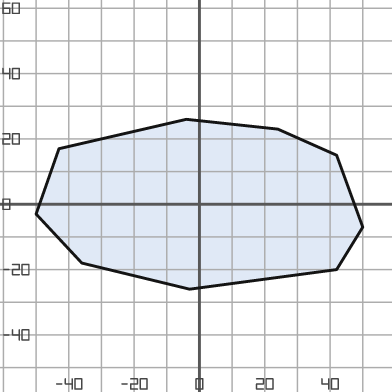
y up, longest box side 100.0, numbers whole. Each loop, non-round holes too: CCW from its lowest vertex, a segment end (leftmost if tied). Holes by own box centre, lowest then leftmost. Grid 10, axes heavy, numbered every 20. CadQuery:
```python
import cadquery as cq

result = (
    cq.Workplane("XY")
    .moveTo(-3.0, -26.0)
    .lineTo(42.0, -20.0)
    .lineTo(50.0, -7.0)
    .lineTo(42.0, 15.0)
    .lineTo(24.0, 23.0)
    .lineTo(-4.0, 26.0)
    .lineTo(-43.0, 17.0)
    .lineTo(-50.0, -3.0)
    .lineTo(-36.0, -18.0)
    .close()
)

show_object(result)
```